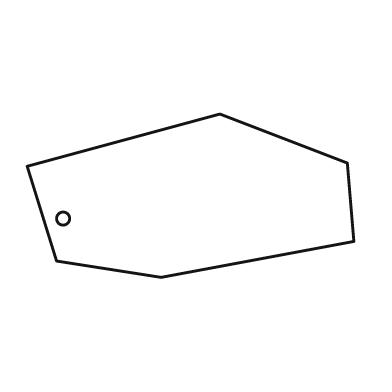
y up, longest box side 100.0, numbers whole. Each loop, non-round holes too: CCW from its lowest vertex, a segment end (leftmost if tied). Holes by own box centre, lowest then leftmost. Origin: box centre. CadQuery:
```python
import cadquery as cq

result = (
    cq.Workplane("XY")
    .moveTo(-9.0, -25.0)
    .lineTo(50.0, -14.0)
    .lineTo(48.0, 10.0)
    .lineTo(9.0, 25.0)
    .lineTo(-50.0, 9.0)
    .lineTo(-41.0, -20.0)
    .close()
    .moveTo(-39.0, -7.0)
    .circle(2.0)
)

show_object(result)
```